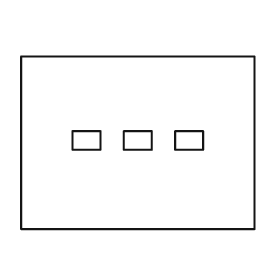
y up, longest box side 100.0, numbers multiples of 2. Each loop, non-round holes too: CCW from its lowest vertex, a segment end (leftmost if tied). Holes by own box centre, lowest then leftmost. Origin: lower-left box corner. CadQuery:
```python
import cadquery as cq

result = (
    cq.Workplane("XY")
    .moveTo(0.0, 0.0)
    .lineTo(100.0, 0.0)
    .lineTo(100.0, 74.0)
    .lineTo(0.0, 74.0)
    .close()
    .moveTo(22.0, 34.0)
    .lineTo(34.0, 34.0)
    .lineTo(34.0, 42.0)
    .lineTo(22.0, 42.0)
    .close()
    .moveTo(44.0, 34.0)
    .lineTo(56.0, 34.0)
    .lineTo(56.0, 42.0)
    .lineTo(44.0, 42.0)
    .close()
    .moveTo(66.0, 34.0)
    .lineTo(78.0, 34.0)
    .lineTo(78.0, 42.0)
    .lineTo(66.0, 42.0)
    .close()
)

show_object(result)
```